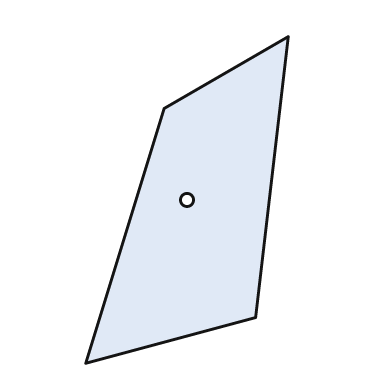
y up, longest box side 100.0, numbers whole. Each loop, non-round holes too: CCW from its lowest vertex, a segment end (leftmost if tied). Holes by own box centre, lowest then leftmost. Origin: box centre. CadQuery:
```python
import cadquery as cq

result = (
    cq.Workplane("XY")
    .moveTo(-31.0, -50.0)
    .lineTo(21.0, -36.0)
    .lineTo(31.0, 50.0)
    .lineTo(-7.0, 28.0)
    .close()
    .moveTo(0.0, 0.0)
    .circle(2.0)
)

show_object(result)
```